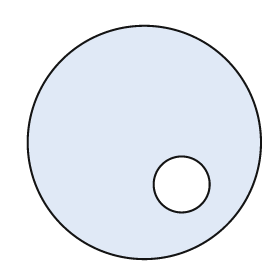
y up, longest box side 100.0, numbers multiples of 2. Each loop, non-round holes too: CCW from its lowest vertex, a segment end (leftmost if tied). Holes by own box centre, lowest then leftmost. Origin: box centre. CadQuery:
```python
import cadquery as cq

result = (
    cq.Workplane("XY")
    .moveTo(0.0, 0.0)
    .circle(50.0)
    .moveTo(16.0, -18.0)
    .circle(12.0)
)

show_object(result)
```